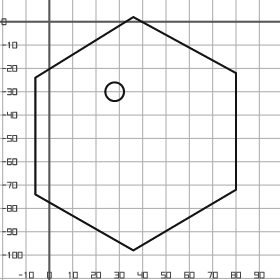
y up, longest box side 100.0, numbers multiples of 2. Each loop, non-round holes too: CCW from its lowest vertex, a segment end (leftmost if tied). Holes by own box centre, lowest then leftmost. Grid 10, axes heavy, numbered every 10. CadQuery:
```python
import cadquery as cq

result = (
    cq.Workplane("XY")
    .moveTo(36.0, -98.0)
    .lineTo(80.0, -72.0)
    .lineTo(80.0, -22.0)
    .lineTo(36.0, 2.0)
    .lineTo(-6.0, -24.0)
    .lineTo(-6.0, -74.0)
    .close()
    .moveTo(28.0, -30.0)
    .circle(4.0)
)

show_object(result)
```